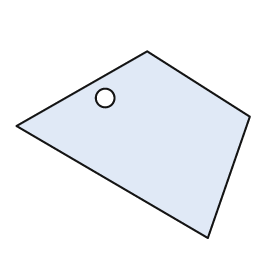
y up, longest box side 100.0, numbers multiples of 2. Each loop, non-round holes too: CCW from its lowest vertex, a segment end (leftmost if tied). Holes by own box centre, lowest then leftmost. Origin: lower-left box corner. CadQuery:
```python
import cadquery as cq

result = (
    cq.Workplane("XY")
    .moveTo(82.0, 0.0)
    .lineTo(100.0, 52.0)
    .lineTo(56.0, 80.0)
    .lineTo(0.0, 48.0)
    .close()
    .moveTo(38.0, 60.0)
    .circle(4.0)
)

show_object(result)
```